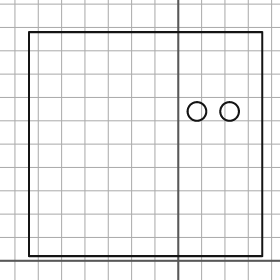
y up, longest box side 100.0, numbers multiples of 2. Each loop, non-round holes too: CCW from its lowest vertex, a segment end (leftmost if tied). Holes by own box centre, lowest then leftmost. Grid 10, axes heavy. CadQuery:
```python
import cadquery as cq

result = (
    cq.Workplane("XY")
    .moveTo(-64.0, 2.0)
    .lineTo(36.0, 2.0)
    .lineTo(36.0, 98.0)
    .lineTo(-64.0, 98.0)
    .close()
    .moveTo(8.0, 64.0)
    .circle(4.0)
    .moveTo(22.0, 64.0)
    .circle(4.0)
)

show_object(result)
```